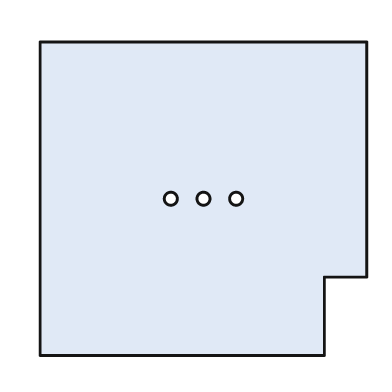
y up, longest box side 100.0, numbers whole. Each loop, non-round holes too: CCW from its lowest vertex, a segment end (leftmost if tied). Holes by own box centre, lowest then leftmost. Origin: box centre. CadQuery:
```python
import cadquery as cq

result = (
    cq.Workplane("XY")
    .moveTo(-50.0, -48.0)
    .lineTo(37.0, -48.0)
    .lineTo(37.0, -24.0)
    .lineTo(50.0, -24.0)
    .lineTo(50.0, 48.0)
    .lineTo(-50.0, 48.0)
    .close()
    .moveTo(-10.0, 0.0)
    .circle(2.0)
    .moveTo(0.0, 0.0)
    .circle(2.0)
    .moveTo(10.0, 0.0)
    .circle(2.0)
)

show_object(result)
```